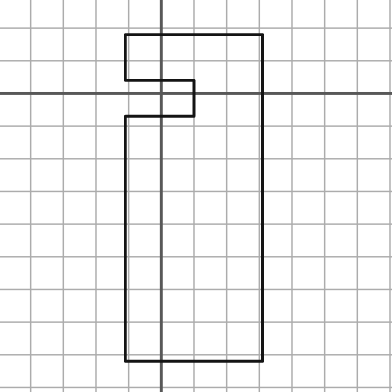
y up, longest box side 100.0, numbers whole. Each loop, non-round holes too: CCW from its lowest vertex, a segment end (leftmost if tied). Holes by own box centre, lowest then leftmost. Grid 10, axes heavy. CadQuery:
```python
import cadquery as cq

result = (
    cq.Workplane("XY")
    .moveTo(-11.0, -82.0)
    .lineTo(31.0, -82.0)
    .lineTo(31.0, 18.0)
    .lineTo(-11.0, 18.0)
    .lineTo(-11.0, 4.0)
    .lineTo(10.0, 4.0)
    .lineTo(10.0, -7.0)
    .lineTo(-11.0, -7.0)
    .close()
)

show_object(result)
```